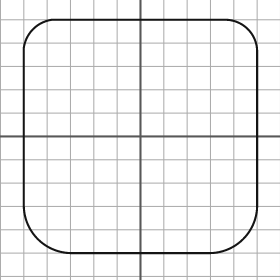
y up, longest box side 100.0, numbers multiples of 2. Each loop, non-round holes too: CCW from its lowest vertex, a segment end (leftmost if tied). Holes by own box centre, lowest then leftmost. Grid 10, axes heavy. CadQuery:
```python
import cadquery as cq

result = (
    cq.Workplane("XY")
    .moveTo(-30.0, -50.0)
    .lineTo(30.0, -50.0)
    .threePointArc((44.0, -44.0), (50.0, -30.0))
    .lineTo(50.0, 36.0)
    .threePointArc((46.0, 46.0), (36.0, 50.0))
    .lineTo(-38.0, 50.0)
    .threePointArc((-46.0, 46.0), (-50.0, 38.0))
    .lineTo(-50.0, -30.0)
    .threePointArc((-44.0, -44.0), (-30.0, -50.0))
    .close()
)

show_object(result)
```